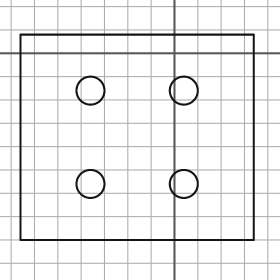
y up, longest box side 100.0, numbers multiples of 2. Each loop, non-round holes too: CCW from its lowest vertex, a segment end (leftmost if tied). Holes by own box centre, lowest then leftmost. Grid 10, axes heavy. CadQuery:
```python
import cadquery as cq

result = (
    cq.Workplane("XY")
    .moveTo(-66.0, -80.0)
    .lineTo(34.0, -80.0)
    .lineTo(34.0, 8.0)
    .lineTo(-66.0, 8.0)
    .close()
    .moveTo(-36.0, -56.0)
    .circle(6.0)
    .moveTo(4.0, -56.0)
    .circle(6.0)
    .moveTo(-36.0, -16.0)
    .circle(6.0)
    .moveTo(4.0, -16.0)
    .circle(6.0)
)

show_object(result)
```